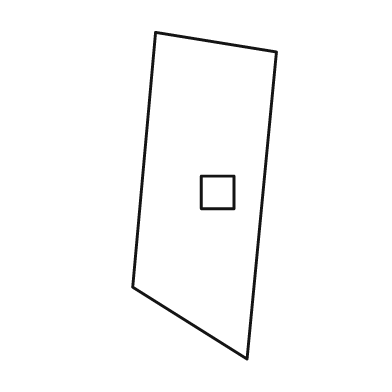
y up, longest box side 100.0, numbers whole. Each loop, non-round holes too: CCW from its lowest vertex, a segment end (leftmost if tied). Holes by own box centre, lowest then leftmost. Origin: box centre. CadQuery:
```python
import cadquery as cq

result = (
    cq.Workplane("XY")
    .moveTo(13.0, -50.0)
    .lineTo(22.0, 44.0)
    .lineTo(-15.0, 50.0)
    .lineTo(-22.0, -28.0)
    .close()
    .moveTo(-1.0, -4.0)
    .lineTo(9.0, -4.0)
    .lineTo(9.0, 6.0)
    .lineTo(-1.0, 6.0)
    .close()
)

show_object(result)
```